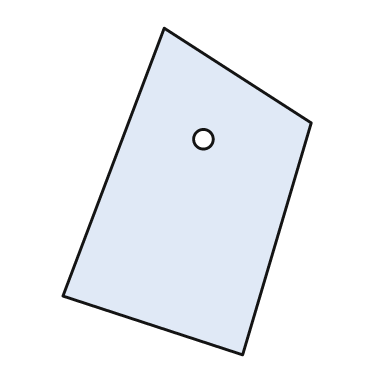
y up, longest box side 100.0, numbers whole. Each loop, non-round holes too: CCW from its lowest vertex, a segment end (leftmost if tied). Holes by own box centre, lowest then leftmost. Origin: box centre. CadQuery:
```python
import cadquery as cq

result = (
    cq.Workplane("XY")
    .moveTo(17.0, -50.0)
    .lineTo(38.0, 21.0)
    .lineTo(-7.0, 50.0)
    .lineTo(-38.0, -32.0)
    .close()
    .moveTo(5.0, 16.0)
    .circle(3.0)
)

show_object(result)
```